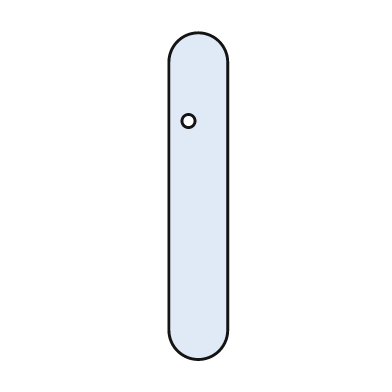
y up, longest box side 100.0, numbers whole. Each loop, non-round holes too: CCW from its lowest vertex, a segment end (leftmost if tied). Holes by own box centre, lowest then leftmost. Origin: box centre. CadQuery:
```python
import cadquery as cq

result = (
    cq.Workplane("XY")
    .moveTo(-9.0, -41.0)
    .threePointArc((0.0, -50.0), (9.0, -41.0))
    .lineTo(9.0, 41.0)
    .threePointArc((0.0, 50.0), (-9.0, 41.0))
    .close()
    .moveTo(-3.0, 23.0)
    .circle(2.0)
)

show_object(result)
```